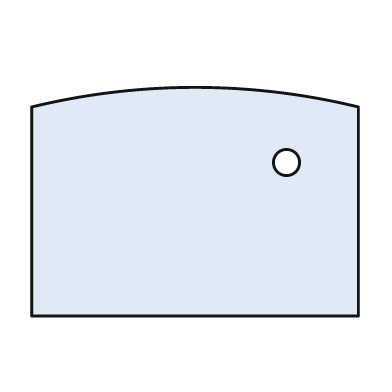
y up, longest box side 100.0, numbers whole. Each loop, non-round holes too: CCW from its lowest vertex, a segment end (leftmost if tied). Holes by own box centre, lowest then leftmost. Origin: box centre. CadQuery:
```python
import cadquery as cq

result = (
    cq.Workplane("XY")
    .moveTo(-50.0, -35.0)
    .lineTo(50.0, -35.0)
    .lineTo(50.0, 29.0)
    .threePointArc((0.0, 35.0), (-50.0, 29.0))
    .close()
    .moveTo(28.0, 12.0)
    .circle(4.0)
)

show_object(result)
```